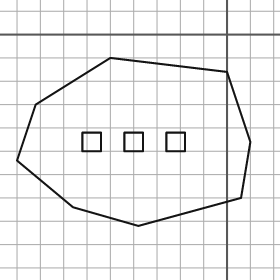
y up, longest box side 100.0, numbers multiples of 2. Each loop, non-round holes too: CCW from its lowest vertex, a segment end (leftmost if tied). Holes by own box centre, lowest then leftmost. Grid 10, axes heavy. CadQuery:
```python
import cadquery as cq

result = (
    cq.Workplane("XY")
    .moveTo(-38.0, -82.0)
    .lineTo(6.0, -70.0)
    .lineTo(10.0, -46.0)
    .lineTo(0.0, -16.0)
    .lineTo(-50.0, -10.0)
    .lineTo(-82.0, -30.0)
    .lineTo(-90.0, -54.0)
    .lineTo(-66.0, -74.0)
    .close()
    .moveTo(-62.0, -50.0)
    .lineTo(-54.0, -50.0)
    .lineTo(-54.0, -42.0)
    .lineTo(-62.0, -42.0)
    .close()
    .moveTo(-44.0, -50.0)
    .lineTo(-36.0, -50.0)
    .lineTo(-36.0, -42.0)
    .lineTo(-44.0, -42.0)
    .close()
    .moveTo(-26.0, -50.0)
    .lineTo(-18.0, -50.0)
    .lineTo(-18.0, -42.0)
    .lineTo(-26.0, -42.0)
    .close()
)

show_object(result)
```